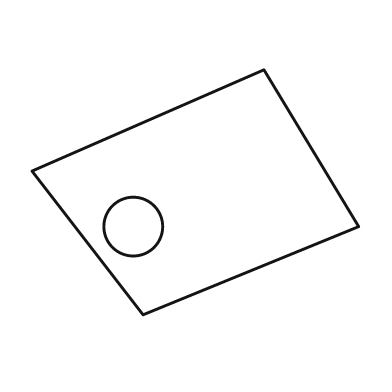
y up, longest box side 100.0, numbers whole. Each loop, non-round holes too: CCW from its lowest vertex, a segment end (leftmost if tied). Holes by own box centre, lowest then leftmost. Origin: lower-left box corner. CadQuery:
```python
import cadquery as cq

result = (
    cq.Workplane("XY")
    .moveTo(34.0, 0.0)
    .lineTo(100.0, 27.0)
    .lineTo(71.0, 75.0)
    .lineTo(0.0, 44.0)
    .close()
    .moveTo(31.0, 27.0)
    .circle(9.0)
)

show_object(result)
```